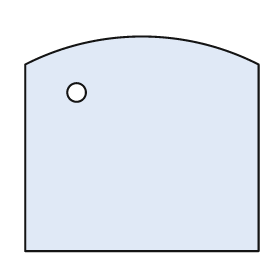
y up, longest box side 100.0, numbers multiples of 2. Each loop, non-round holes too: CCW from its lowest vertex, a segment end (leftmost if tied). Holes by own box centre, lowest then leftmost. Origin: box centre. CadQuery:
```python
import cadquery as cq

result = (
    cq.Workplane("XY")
    .moveTo(-50.0, -46.0)
    .lineTo(50.0, -46.0)
    .lineTo(50.0, 34.0)
    .threePointArc((0.0, 46.0), (-50.0, 34.0))
    .close()
    .moveTo(-28.0, 22.0)
    .circle(4.0)
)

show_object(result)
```